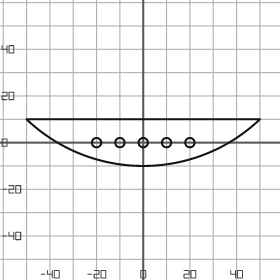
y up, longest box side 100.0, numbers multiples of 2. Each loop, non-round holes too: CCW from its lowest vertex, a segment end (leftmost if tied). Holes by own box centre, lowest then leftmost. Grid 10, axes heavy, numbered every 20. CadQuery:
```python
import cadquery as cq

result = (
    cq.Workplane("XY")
    .moveTo(-50.0, 10.0)
    .threePointArc((0.0, -10.0), (50.0, 10.0))
    .close()
    .moveTo(-20.0, 0.0)
    .circle(2.0)
    .moveTo(-10.0, 0.0)
    .circle(2.0)
    .moveTo(0.0, 0.0)
    .circle(2.0)
    .moveTo(10.0, 0.0)
    .circle(2.0)
    .moveTo(20.0, 0.0)
    .circle(2.0)
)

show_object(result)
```